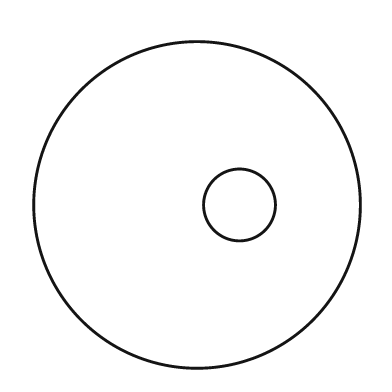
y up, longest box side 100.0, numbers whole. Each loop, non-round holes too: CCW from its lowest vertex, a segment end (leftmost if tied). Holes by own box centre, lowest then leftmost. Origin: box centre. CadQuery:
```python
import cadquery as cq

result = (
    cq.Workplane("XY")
    .moveTo(0.0, 0.0)
    .circle(50.0)
    .moveTo(13.0, 0.0)
    .circle(11.0)
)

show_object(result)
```